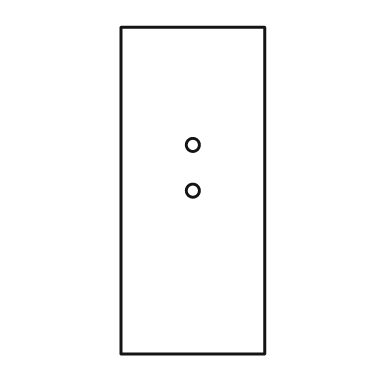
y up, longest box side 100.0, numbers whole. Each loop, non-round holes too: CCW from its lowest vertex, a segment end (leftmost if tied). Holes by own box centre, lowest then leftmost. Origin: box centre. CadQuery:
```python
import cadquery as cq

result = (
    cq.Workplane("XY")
    .moveTo(-22.0, -50.0)
    .lineTo(22.0, -50.0)
    .lineTo(22.0, 50.0)
    .lineTo(-22.0, 50.0)
    .close()
    .moveTo(0.0, 0.0)
    .circle(2.0)
    .moveTo(0.0, 14.0)
    .circle(2.0)
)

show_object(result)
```